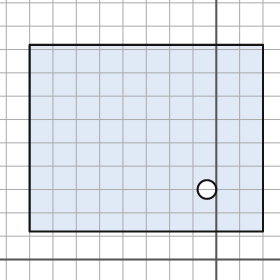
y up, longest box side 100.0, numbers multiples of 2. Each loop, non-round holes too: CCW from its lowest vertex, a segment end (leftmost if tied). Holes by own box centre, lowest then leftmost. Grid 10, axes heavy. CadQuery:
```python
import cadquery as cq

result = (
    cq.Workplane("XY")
    .moveTo(-80.0, 12.0)
    .lineTo(20.0, 12.0)
    .lineTo(20.0, 92.0)
    .lineTo(-80.0, 92.0)
    .close()
    .moveTo(-4.0, 30.0)
    .circle(4.0)
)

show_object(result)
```